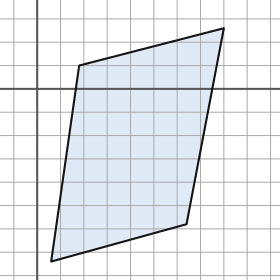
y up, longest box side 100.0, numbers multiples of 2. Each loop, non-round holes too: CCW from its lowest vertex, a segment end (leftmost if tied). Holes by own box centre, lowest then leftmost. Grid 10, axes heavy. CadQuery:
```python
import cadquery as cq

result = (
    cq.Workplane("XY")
    .moveTo(6.0, -74.0)
    .lineTo(64.0, -58.0)
    .lineTo(80.0, 26.0)
    .lineTo(18.0, 10.0)
    .close()
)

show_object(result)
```